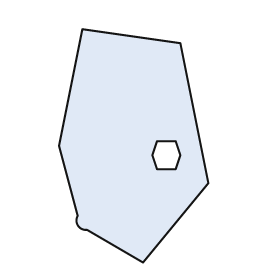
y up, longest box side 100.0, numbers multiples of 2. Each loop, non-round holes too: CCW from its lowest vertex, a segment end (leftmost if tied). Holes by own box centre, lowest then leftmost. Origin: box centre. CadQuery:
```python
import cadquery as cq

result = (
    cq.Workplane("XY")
    .moveTo(4.0, -50.0)
    .lineTo(32.0, -16.0)
    .lineTo(20.0, 44.0)
    .lineTo(-22.0, 50.0)
    .lineTo(-32.0, 0.0)
    .lineTo(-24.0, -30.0)
    .threePointArc((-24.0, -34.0), (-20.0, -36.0))
    .close()
    .moveTo(10.0, -10.0)
    .lineTo(18.0, -10.0)
    .lineTo(20.0, -4.0)
    .lineTo(18.0, 2.0)
    .lineTo(10.0, 2.0)
    .lineTo(8.0, -4.0)
    .close()
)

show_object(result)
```